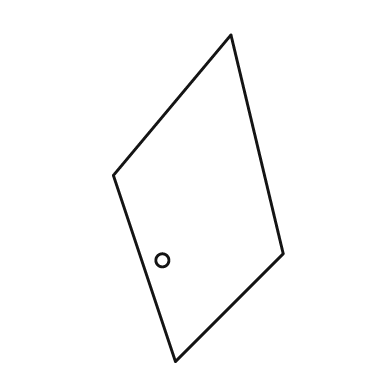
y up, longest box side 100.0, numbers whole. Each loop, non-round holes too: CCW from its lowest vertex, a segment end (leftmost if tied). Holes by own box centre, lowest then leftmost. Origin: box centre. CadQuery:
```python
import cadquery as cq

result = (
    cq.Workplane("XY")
    .moveTo(-7.0, -50.0)
    .lineTo(26.0, -17.0)
    .lineTo(10.0, 50.0)
    .lineTo(-26.0, 7.0)
    .close()
    .moveTo(-11.0, -19.0)
    .circle(2.0)
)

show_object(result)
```